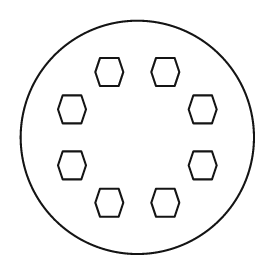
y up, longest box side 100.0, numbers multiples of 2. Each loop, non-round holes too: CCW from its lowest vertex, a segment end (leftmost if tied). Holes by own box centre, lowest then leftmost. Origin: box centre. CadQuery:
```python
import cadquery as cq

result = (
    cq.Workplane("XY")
    .moveTo(0.0, 0.0)
    .circle(50.0)
    .moveTo(-16.0, -34.0)
    .lineTo(-8.0, -34.0)
    .lineTo(-6.0, -28.0)
    .lineTo(-8.0, -22.0)
    .lineTo(-16.0, -22.0)
    .lineTo(-18.0, -28.0)
    .close()
    .moveTo(8.0, -34.0)
    .lineTo(16.0, -34.0)
    .lineTo(18.0, -28.0)
    .lineTo(16.0, -22.0)
    .lineTo(8.0, -22.0)
    .lineTo(6.0, -28.0)
    .close()
    .moveTo(-32.0, -18.0)
    .lineTo(-24.0, -18.0)
    .lineTo(-22.0, -12.0)
    .lineTo(-24.0, -6.0)
    .lineTo(-32.0, -6.0)
    .lineTo(-34.0, -12.0)
    .close()
    .moveTo(24.0, -18.0)
    .lineTo(32.0, -18.0)
    .lineTo(34.0, -12.0)
    .lineTo(32.0, -6.0)
    .lineTo(24.0, -6.0)
    .lineTo(22.0, -12.0)
    .close()
    .moveTo(-32.0, 6.0)
    .lineTo(-24.0, 6.0)
    .lineTo(-22.0, 12.0)
    .lineTo(-24.0, 18.0)
    .lineTo(-32.0, 18.0)
    .lineTo(-34.0, 12.0)
    .close()
    .moveTo(24.0, 6.0)
    .lineTo(32.0, 6.0)
    .lineTo(34.0, 12.0)
    .lineTo(32.0, 18.0)
    .lineTo(24.0, 18.0)
    .lineTo(22.0, 12.0)
    .close()
    .moveTo(-16.0, 22.0)
    .lineTo(-8.0, 22.0)
    .lineTo(-6.0, 28.0)
    .lineTo(-8.0, 34.0)
    .lineTo(-16.0, 34.0)
    .lineTo(-18.0, 28.0)
    .close()
    .moveTo(8.0, 22.0)
    .lineTo(16.0, 22.0)
    .lineTo(18.0, 28.0)
    .lineTo(16.0, 34.0)
    .lineTo(8.0, 34.0)
    .lineTo(6.0, 28.0)
    .close()
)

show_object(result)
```